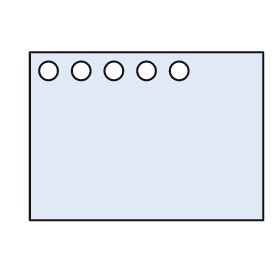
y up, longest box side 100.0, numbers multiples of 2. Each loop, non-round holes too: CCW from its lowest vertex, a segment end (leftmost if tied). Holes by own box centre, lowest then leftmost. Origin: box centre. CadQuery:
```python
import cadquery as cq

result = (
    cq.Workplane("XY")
    .moveTo(-50.0, -36.0)
    .lineTo(50.0, -36.0)
    .lineTo(50.0, 36.0)
    .lineTo(-50.0, 36.0)
    .close()
    .moveTo(-42.0, 28.0)
    .circle(4.0)
    .moveTo(-28.0, 28.0)
    .circle(4.0)
    .moveTo(-14.0, 28.0)
    .circle(4.0)
    .moveTo(0.0, 28.0)
    .circle(4.0)
    .moveTo(14.0, 28.0)
    .circle(4.0)
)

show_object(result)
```